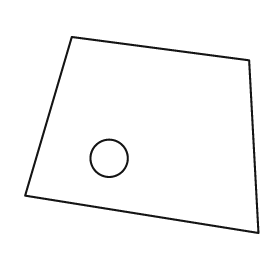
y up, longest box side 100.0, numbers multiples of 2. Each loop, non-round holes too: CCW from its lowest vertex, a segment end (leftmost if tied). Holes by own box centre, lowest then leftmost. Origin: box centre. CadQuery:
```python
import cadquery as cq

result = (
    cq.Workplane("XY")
    .moveTo(50.0, -42.0)
    .lineTo(46.0, 32.0)
    .lineTo(-30.0, 42.0)
    .lineTo(-50.0, -26.0)
    .close()
    .moveTo(-14.0, -10.0)
    .circle(8.0)
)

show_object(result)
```